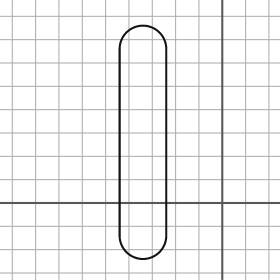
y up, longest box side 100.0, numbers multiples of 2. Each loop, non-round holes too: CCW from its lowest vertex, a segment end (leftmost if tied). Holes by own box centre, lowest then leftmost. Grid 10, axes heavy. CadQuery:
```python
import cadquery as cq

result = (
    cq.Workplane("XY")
    .moveTo(-44.0, -14.0)
    .threePointArc((-34.0, -24.0), (-24.0, -14.0))
    .lineTo(-24.0, 66.0)
    .threePointArc((-34.0, 76.0), (-44.0, 66.0))
    .close()
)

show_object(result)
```